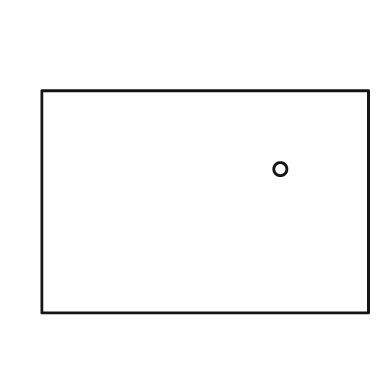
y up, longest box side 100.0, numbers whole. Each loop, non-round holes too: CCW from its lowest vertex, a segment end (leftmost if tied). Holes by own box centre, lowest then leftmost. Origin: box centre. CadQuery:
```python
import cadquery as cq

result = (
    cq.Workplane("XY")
    .moveTo(-50.0, -34.0)
    .lineTo(50.0, -34.0)
    .lineTo(50.0, 34.0)
    .lineTo(-50.0, 34.0)
    .close()
    .moveTo(23.0, 10.0)
    .circle(2.0)
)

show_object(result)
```